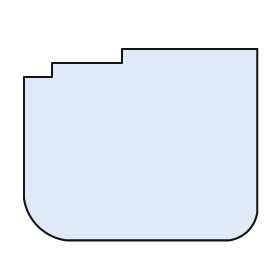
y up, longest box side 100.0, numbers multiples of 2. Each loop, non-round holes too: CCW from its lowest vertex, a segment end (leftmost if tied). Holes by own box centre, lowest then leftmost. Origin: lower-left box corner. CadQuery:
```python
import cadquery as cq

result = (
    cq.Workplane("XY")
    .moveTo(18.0, 0.0)
    .lineTo(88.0, 0.0)
    .threePointArc((96.0, 4.0), (100.0, 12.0))
    .lineTo(100.0, 82.0)
    .lineTo(42.0, 82.0)
    .lineTo(42.0, 76.0)
    .lineTo(12.0, 76.0)
    .lineTo(12.0, 70.0)
    .lineTo(0.0, 70.0)
    .lineTo(0.0, 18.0)
    .threePointArc((6.0, 6.0), (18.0, 0.0))
    .close()
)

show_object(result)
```